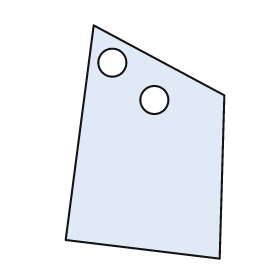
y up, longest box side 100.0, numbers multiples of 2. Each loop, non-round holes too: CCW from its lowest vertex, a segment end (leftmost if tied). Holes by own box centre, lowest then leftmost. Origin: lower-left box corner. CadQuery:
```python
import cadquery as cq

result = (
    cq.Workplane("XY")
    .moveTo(66.0, 0.0)
    .lineTo(68.0, 70.0)
    .lineTo(12.0, 100.0)
    .lineTo(0.0, 8.0)
    .close()
    .moveTo(38.0, 68.0)
    .circle(6.0)
    .moveTo(20.0, 84.0)
    .circle(6.0)
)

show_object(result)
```